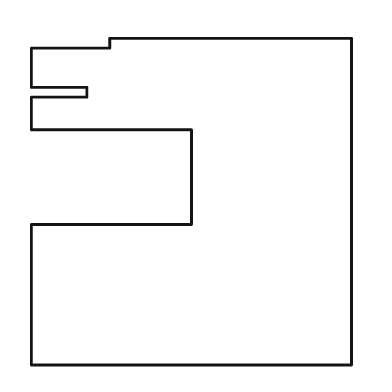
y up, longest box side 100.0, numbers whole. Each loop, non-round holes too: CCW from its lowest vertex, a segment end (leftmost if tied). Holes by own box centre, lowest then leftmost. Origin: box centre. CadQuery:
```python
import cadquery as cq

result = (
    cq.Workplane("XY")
    .moveTo(-49.0, -50.0)
    .lineTo(49.0, -50.0)
    .lineTo(49.0, 50.0)
    .lineTo(-25.0, 50.0)
    .lineTo(-25.0, 47.0)
    .lineTo(-49.0, 47.0)
    .lineTo(-49.0, 35.0)
    .lineTo(-32.0, 35.0)
    .lineTo(-32.0, 32.0)
    .lineTo(-49.0, 32.0)
    .lineTo(-49.0, 22.0)
    .lineTo(0.0, 22.0)
    .lineTo(0.0, -7.0)
    .lineTo(-49.0, -7.0)
    .close()
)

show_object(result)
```